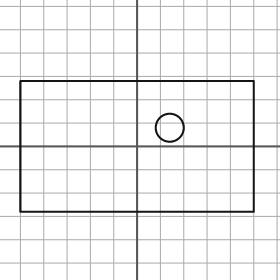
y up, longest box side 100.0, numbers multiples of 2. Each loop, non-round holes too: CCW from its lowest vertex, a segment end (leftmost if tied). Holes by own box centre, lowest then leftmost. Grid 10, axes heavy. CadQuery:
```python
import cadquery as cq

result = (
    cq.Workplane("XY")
    .moveTo(-50.0, -28.0)
    .lineTo(50.0, -28.0)
    .lineTo(50.0, 28.0)
    .lineTo(-50.0, 28.0)
    .close()
    .moveTo(14.0, 8.0)
    .circle(6.0)
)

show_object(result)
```